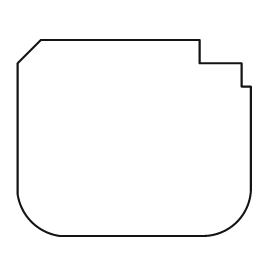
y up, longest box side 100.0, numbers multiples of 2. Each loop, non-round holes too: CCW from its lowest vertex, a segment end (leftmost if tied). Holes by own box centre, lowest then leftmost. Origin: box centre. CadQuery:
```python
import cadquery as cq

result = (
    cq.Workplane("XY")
    .moveTo(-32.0, -42.0)
    .lineTo(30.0, -42.0)
    .threePointArc((44.0, -36.0), (50.0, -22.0))
    .lineTo(50.0, 22.0)
    .lineTo(46.0, 22.0)
    .lineTo(46.0, 32.0)
    .lineTo(28.0, 32.0)
    .lineTo(28.0, 42.0)
    .lineTo(-40.0, 42.0)
    .lineTo(-50.0, 32.0)
    .lineTo(-50.0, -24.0)
    .threePointArc((-44.0, -36.0), (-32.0, -42.0))
    .close()
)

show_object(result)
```